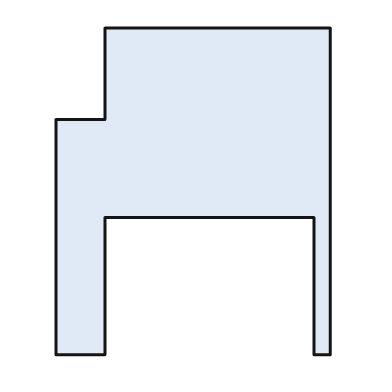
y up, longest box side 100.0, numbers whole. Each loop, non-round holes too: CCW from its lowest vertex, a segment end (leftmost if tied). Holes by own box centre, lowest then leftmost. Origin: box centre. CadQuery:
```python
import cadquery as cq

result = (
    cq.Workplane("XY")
    .moveTo(-42.0, -50.0)
    .lineTo(-27.0, -50.0)
    .lineTo(-27.0, -8.0)
    .lineTo(37.0, -8.0)
    .lineTo(37.0, -50.0)
    .lineTo(42.0, -50.0)
    .lineTo(42.0, 50.0)
    .lineTo(-27.0, 50.0)
    .lineTo(-27.0, 22.0)
    .lineTo(-42.0, 22.0)
    .close()
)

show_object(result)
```